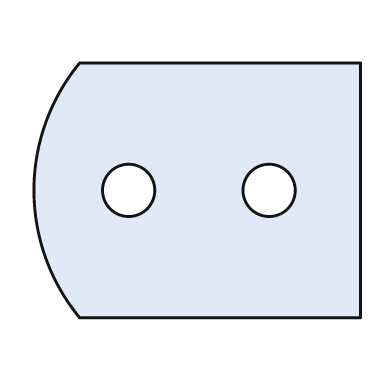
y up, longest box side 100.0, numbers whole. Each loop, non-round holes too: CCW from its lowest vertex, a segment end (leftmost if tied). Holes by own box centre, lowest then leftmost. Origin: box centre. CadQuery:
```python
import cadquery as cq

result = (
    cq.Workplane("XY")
    .moveTo(-36.0, -39.0)
    .lineTo(50.0, -39.0)
    .lineTo(50.0, 39.0)
    .lineTo(-36.0, 39.0)
    .threePointArc((-50.0, 0.0), (-36.0, -39.0))
    .close()
    .moveTo(-21.0, 0.0)
    .circle(8.0)
    .moveTo(22.0, 0.0)
    .circle(8.0)
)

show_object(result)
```